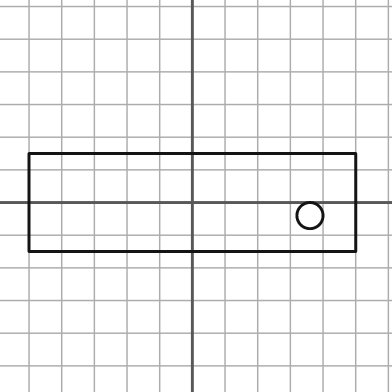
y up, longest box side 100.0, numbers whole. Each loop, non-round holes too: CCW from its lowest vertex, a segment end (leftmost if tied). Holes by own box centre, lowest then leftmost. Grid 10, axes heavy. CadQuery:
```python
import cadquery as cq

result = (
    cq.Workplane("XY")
    .moveTo(-50.0, -15.0)
    .lineTo(50.0, -15.0)
    .lineTo(50.0, 15.0)
    .lineTo(-50.0, 15.0)
    .close()
    .moveTo(36.0, -4.0)
    .circle(4.0)
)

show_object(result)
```